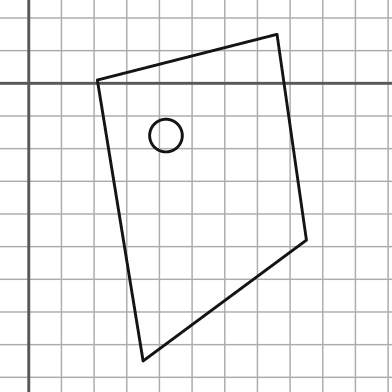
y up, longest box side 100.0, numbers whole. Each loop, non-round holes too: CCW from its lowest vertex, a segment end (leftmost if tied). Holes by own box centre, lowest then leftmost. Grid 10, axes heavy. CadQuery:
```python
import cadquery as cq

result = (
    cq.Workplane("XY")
    .moveTo(35.0, -85.0)
    .lineTo(85.0, -48.0)
    .lineTo(76.0, 15.0)
    .lineTo(21.0, 1.0)
    .close()
    .moveTo(42.0, -16.0)
    .circle(5.0)
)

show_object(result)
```